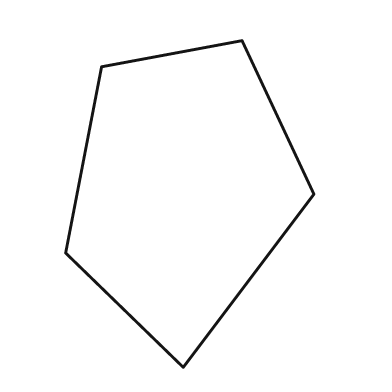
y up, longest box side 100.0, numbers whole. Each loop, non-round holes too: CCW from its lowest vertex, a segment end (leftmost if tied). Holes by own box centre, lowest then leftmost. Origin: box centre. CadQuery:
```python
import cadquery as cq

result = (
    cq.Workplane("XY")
    .moveTo(-2.0, -50.0)
    .lineTo(38.0, 3.0)
    .lineTo(16.0, 50.0)
    .lineTo(-27.0, 42.0)
    .lineTo(-38.0, -15.0)
    .close()
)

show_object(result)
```